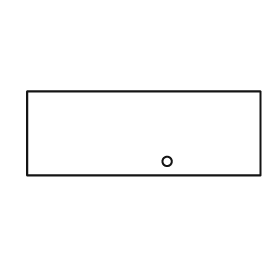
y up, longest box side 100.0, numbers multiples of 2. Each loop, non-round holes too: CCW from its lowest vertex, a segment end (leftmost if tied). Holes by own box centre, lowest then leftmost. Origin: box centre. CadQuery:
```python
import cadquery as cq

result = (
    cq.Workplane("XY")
    .moveTo(-50.0, -18.0)
    .lineTo(50.0, -18.0)
    .lineTo(50.0, 18.0)
    .lineTo(-50.0, 18.0)
    .close()
    .moveTo(10.0, -12.0)
    .circle(2.0)
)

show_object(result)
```